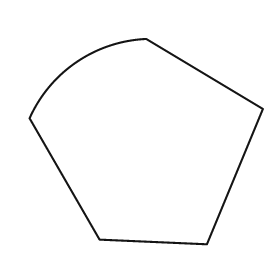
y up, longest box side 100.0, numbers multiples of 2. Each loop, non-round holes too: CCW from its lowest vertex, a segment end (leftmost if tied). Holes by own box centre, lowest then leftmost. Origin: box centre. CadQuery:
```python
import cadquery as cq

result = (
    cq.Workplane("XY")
    .moveTo(26.0, -44.0)
    .lineTo(50.0, 14.0)
    .lineTo(0.0, 44.0)
    .threePointArc((-30.0, 34.0), (-50.0, 10.0))
    .lineTo(-20.0, -42.0)
    .close()
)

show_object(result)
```